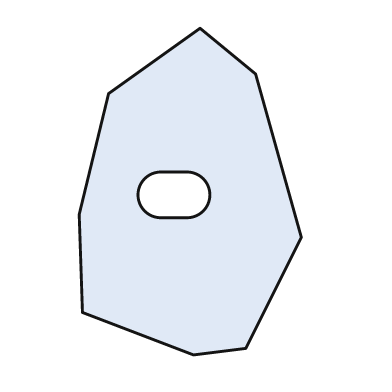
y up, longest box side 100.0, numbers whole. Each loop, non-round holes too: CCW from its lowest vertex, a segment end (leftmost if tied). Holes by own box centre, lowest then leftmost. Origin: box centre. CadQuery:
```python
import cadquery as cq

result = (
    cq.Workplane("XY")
    .moveTo(1.0, -50.0)
    .lineTo(17.0, -48.0)
    .lineTo(34.0, -14.0)
    .lineTo(20.0, 36.0)
    .lineTo(3.0, 50.0)
    .lineTo(-25.0, 30.0)
    .lineTo(-34.0, -7.0)
    .lineTo(-33.0, -37.0)
    .close()
    .moveTo(-9.0, -8.0)
    .lineTo(-1.0, -8.0)
    .threePointArc((6.0, -1.0), (-1.0, 6.0))
    .lineTo(-9.0, 6.0)
    .threePointArc((-16.0, -1.0), (-9.0, -8.0))
    .close()
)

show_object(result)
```